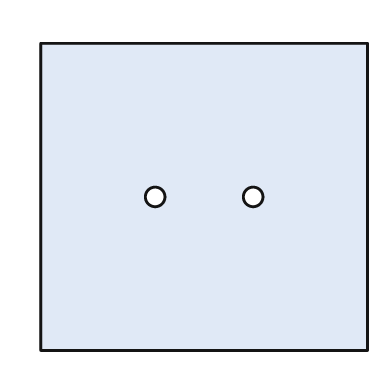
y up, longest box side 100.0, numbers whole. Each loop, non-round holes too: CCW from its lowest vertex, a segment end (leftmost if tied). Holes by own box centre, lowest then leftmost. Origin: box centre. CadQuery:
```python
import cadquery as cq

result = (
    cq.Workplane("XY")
    .moveTo(-50.0, -47.0)
    .lineTo(50.0, -47.0)
    .lineTo(50.0, 47.0)
    .lineTo(-50.0, 47.0)
    .close()
    .moveTo(-15.0, 0.0)
    .circle(3.0)
    .moveTo(15.0, 0.0)
    .circle(3.0)
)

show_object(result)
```